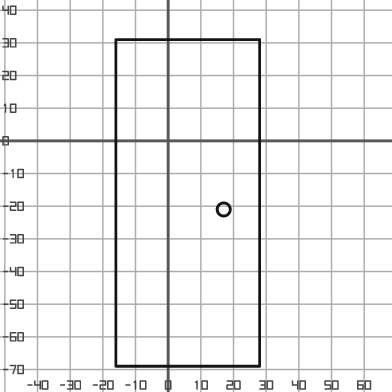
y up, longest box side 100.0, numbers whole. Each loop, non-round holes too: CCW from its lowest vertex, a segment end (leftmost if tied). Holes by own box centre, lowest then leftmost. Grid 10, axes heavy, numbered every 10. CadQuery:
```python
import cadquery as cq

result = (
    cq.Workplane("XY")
    .moveTo(-16.0, -69.0)
    .lineTo(28.0, -69.0)
    .lineTo(28.0, 31.0)
    .lineTo(-16.0, 31.0)
    .close()
    .moveTo(17.0, -21.0)
    .circle(2.0)
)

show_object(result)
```